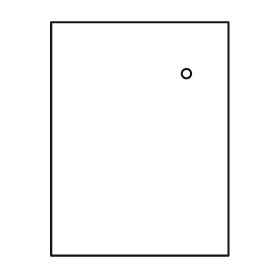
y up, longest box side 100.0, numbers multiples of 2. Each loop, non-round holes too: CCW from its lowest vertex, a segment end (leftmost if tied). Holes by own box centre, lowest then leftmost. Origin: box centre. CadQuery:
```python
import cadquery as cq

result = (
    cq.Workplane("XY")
    .moveTo(-38.0, -50.0)
    .lineTo(38.0, -50.0)
    .lineTo(38.0, 50.0)
    .lineTo(-38.0, 50.0)
    .close()
    .moveTo(20.0, 28.0)
    .circle(2.0)
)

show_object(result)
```